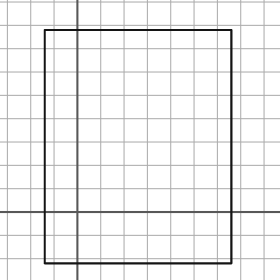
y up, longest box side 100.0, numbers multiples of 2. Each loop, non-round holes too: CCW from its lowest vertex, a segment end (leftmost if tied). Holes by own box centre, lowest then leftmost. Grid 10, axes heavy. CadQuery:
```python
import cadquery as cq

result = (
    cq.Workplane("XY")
    .moveTo(-14.0, -22.0)
    .lineTo(66.0, -22.0)
    .lineTo(66.0, 78.0)
    .lineTo(-14.0, 78.0)
    .close()
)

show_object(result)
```